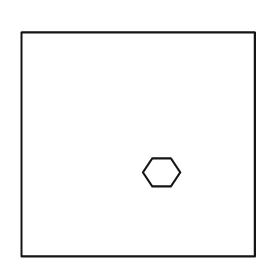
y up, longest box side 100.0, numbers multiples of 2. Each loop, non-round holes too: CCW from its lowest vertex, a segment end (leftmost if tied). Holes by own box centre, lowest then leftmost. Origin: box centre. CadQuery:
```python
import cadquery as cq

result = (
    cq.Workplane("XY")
    .moveTo(-50.0, -48.0)
    .lineTo(50.0, -48.0)
    .lineTo(50.0, 48.0)
    .lineTo(-50.0, 48.0)
    .close()
    .moveTo(6.0, -18.0)
    .lineTo(14.0, -18.0)
    .lineTo(18.0, -12.0)
    .lineTo(14.0, -6.0)
    .lineTo(6.0, -6.0)
    .lineTo(2.0, -12.0)
    .close()
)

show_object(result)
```